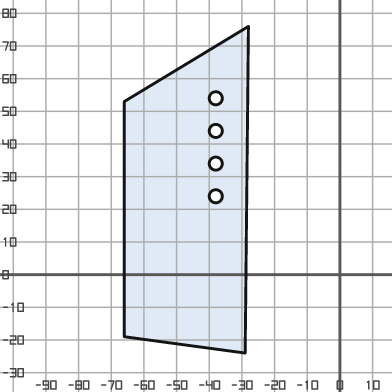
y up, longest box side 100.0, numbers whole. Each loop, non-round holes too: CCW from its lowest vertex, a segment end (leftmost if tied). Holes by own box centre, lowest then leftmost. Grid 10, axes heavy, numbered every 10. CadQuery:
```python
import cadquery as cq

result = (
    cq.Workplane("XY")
    .moveTo(-29.0, -24.0)
    .lineTo(-28.0, 76.0)
    .lineTo(-66.0, 53.0)
    .lineTo(-66.0, -19.0)
    .close()
    .moveTo(-38.0, 24.0)
    .circle(2.0)
    .moveTo(-38.0, 34.0)
    .circle(2.0)
    .moveTo(-38.0, 44.0)
    .circle(2.0)
    .moveTo(-38.0, 54.0)
    .circle(2.0)
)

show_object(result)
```